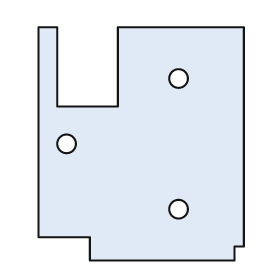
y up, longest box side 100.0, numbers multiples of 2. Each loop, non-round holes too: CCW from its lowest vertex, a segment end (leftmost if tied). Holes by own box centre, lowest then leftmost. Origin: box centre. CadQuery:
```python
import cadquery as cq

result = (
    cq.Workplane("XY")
    .moveTo(-22.0, -50.0)
    .lineTo(40.0, -50.0)
    .lineTo(40.0, -44.0)
    .lineTo(44.0, -44.0)
    .lineTo(44.0, 50.0)
    .lineTo(-10.0, 50.0)
    .lineTo(-10.0, 16.0)
    .lineTo(-36.0, 16.0)
    .lineTo(-36.0, 50.0)
    .lineTo(-44.0, 50.0)
    .lineTo(-44.0, -40.0)
    .lineTo(-22.0, -40.0)
    .close()
    .moveTo(16.0, -28.0)
    .circle(4.0)
    .moveTo(-32.0, 0.0)
    .circle(4.0)
    .moveTo(16.0, 28.0)
    .circle(4.0)
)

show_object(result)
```